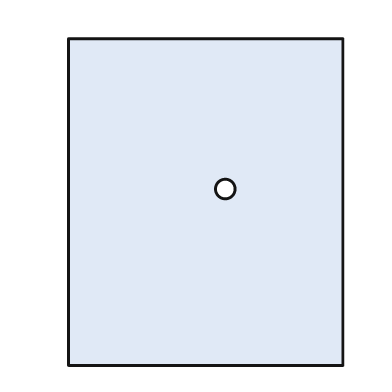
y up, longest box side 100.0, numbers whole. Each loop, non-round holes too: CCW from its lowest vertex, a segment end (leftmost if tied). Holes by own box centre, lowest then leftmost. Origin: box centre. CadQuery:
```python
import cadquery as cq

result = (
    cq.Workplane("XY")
    .moveTo(-42.0, -50.0)
    .lineTo(42.0, -50.0)
    .lineTo(42.0, 50.0)
    .lineTo(-42.0, 50.0)
    .close()
    .moveTo(6.0, 4.0)
    .circle(3.0)
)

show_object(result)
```